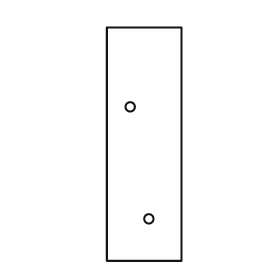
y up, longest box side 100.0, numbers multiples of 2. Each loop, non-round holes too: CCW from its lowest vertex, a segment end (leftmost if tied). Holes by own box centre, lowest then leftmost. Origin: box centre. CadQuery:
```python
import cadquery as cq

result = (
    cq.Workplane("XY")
    .moveTo(-16.0, -50.0)
    .lineTo(16.0, -50.0)
    .lineTo(16.0, 50.0)
    .lineTo(-16.0, 50.0)
    .close()
    .moveTo(2.0, -32.0)
    .circle(2.0)
    .moveTo(-6.0, 16.0)
    .circle(2.0)
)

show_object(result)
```